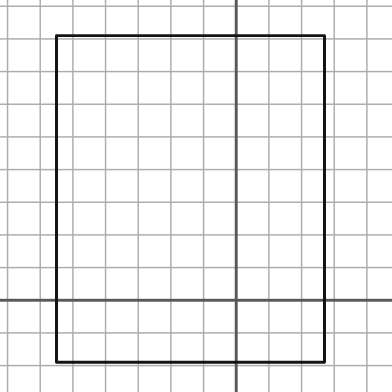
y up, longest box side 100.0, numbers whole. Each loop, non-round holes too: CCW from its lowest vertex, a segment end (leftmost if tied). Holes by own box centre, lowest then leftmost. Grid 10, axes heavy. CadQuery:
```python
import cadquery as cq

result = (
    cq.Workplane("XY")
    .moveTo(-55.0, -19.0)
    .lineTo(27.0, -19.0)
    .lineTo(27.0, 81.0)
    .lineTo(-55.0, 81.0)
    .close()
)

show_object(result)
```